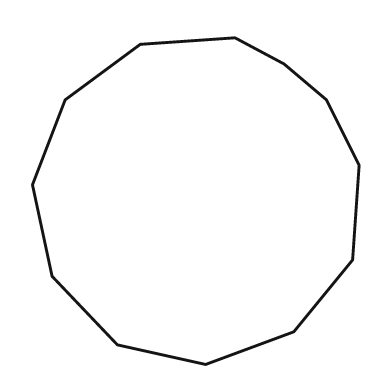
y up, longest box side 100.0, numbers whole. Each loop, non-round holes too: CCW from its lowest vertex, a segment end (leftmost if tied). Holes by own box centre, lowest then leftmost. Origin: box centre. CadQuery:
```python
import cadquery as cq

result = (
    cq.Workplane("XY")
    .moveTo(3.0, -50.0)
    .lineTo(30.0, -40.0)
    .lineTo(48.0, -18.0)
    .lineTo(50.0, 11.0)
    .lineTo(40.0, 31.0)
    .lineTo(27.0, 42.0)
    .lineTo(12.0, 50.0)
    .lineTo(-17.0, 48.0)
    .lineTo(-40.0, 31.0)
    .lineTo(-50.0, 5.0)
    .lineTo(-44.0, -23.0)
    .lineTo(-24.0, -44.0)
    .close()
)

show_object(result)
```